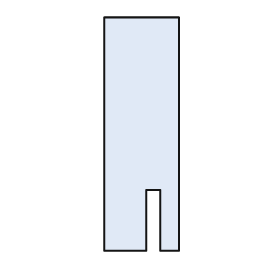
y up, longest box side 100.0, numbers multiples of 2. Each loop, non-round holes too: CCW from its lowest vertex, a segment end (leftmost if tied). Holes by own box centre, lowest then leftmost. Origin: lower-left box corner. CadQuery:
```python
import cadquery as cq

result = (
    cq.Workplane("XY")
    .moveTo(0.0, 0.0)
    .lineTo(18.0, 0.0)
    .lineTo(18.0, 26.0)
    .lineTo(24.0, 26.0)
    .lineTo(24.0, 0.0)
    .lineTo(32.0, 0.0)
    .lineTo(32.0, 100.0)
    .lineTo(0.0, 100.0)
    .close()
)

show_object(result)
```